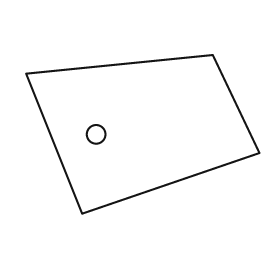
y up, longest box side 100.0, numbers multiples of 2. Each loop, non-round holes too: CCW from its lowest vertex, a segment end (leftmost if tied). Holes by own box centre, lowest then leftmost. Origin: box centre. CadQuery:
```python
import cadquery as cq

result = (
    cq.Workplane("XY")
    .moveTo(-26.0, -34.0)
    .lineTo(50.0, -8.0)
    .lineTo(30.0, 34.0)
    .lineTo(-50.0, 26.0)
    .close()
    .moveTo(-20.0, 0.0)
    .circle(4.0)
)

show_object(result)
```